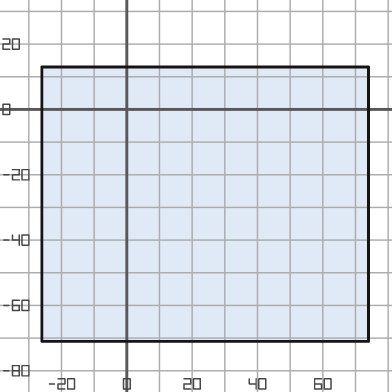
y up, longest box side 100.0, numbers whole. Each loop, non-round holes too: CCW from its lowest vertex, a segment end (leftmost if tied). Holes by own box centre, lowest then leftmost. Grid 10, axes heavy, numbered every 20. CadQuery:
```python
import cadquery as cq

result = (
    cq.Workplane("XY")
    .moveTo(-26.0, -71.0)
    .lineTo(74.0, -71.0)
    .lineTo(74.0, 13.0)
    .lineTo(-26.0, 13.0)
    .close()
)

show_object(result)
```